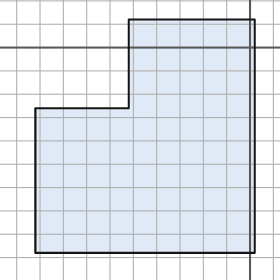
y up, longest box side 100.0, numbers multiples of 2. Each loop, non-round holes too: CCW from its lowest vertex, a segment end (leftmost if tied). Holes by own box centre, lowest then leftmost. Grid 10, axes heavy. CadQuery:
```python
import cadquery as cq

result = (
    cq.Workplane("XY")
    .moveTo(-92.0, -88.0)
    .lineTo(2.0, -88.0)
    .lineTo(2.0, 12.0)
    .lineTo(-52.0, 12.0)
    .lineTo(-52.0, -26.0)
    .lineTo(-92.0, -26.0)
    .close()
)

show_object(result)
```